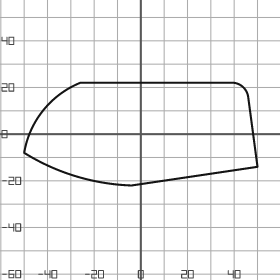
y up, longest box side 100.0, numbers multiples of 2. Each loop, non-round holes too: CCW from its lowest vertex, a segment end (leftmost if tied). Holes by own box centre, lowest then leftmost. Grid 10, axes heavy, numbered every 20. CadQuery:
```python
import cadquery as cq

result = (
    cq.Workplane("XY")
    .moveTo(-4.0, -22.0)
    .lineTo(50.0, -14.0)
    .lineTo(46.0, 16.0)
    .threePointArc((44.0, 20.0), (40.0, 22.0))
    .lineTo(-26.0, 22.0)
    .threePointArc((-42.0, 10.0), (-50.0, -8.0))
    .threePointArc((-28.0, -18.0), (-4.0, -22.0))
    .close()
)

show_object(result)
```